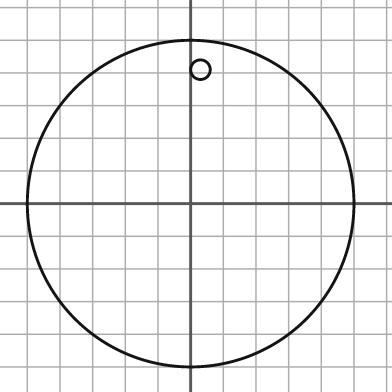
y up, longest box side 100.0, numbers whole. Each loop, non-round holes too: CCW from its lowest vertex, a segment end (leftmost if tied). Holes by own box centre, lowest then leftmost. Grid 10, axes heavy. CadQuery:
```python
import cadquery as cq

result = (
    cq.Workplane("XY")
    .moveTo(0.0, 0.0)
    .circle(50.0)
    .moveTo(3.0, 41.0)
    .circle(3.0)
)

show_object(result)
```